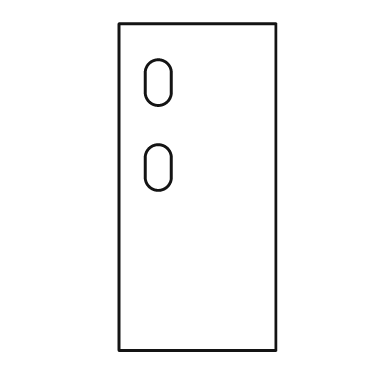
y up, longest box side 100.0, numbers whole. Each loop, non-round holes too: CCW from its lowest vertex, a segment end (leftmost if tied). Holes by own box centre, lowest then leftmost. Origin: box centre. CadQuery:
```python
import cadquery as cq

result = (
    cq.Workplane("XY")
    .moveTo(-24.0, -50.0)
    .lineTo(24.0, -50.0)
    .lineTo(24.0, 50.0)
    .lineTo(-24.0, 50.0)
    .close()
    .moveTo(-16.0, 3.0)
    .threePointArc((-12.0, -1.0), (-8.0, 3.0))
    .lineTo(-8.0, 9.0)
    .threePointArc((-12.0, 13.0), (-16.0, 9.0))
    .close()
    .moveTo(-16.0, 29.0)
    .threePointArc((-12.0, 25.0), (-8.0, 29.0))
    .lineTo(-8.0, 35.0)
    .threePointArc((-12.0, 39.0), (-16.0, 35.0))
    .close()
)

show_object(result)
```